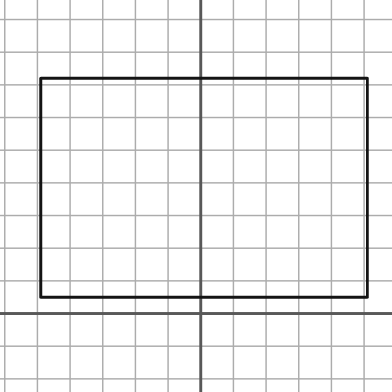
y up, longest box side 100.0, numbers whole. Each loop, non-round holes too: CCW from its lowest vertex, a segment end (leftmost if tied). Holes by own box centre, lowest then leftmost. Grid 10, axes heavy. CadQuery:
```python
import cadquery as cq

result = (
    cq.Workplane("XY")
    .moveTo(-49.0, 5.0)
    .lineTo(51.0, 5.0)
    .lineTo(51.0, 72.0)
    .lineTo(-49.0, 72.0)
    .close()
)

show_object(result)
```